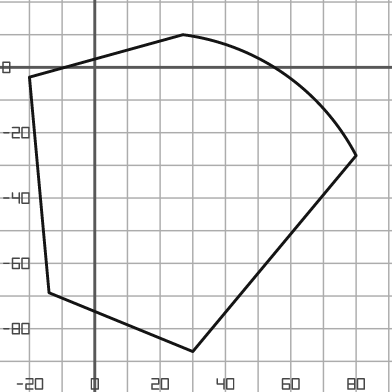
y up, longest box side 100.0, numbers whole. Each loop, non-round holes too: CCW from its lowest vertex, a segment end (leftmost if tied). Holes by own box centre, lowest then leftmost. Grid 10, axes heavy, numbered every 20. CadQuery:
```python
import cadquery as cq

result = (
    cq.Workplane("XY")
    .moveTo(30.0, -87.0)
    .lineTo(80.0, -27.0)
    .threePointArc((58.0, -2.0), (27.0, 10.0))
    .lineTo(-20.0, -3.0)
    .lineTo(-14.0, -69.0)
    .close()
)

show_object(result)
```